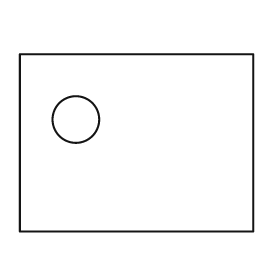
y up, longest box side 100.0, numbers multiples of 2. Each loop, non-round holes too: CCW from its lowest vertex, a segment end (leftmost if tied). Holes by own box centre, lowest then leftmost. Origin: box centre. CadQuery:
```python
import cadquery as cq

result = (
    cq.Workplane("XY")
    .moveTo(-50.0, -38.0)
    .lineTo(50.0, -38.0)
    .lineTo(50.0, 38.0)
    .lineTo(-50.0, 38.0)
    .close()
    .moveTo(-26.0, 10.0)
    .circle(10.0)
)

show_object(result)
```